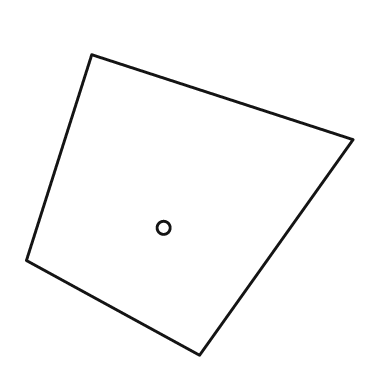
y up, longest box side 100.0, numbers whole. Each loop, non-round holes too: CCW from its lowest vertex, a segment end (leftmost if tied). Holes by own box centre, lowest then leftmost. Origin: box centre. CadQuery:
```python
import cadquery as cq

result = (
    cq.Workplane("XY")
    .moveTo(3.0, -46.0)
    .lineTo(50.0, 20.0)
    .lineTo(-30.0, 46.0)
    .lineTo(-50.0, -17.0)
    .close()
    .moveTo(-8.0, -7.0)
    .circle(2.0)
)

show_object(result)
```